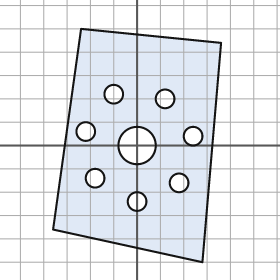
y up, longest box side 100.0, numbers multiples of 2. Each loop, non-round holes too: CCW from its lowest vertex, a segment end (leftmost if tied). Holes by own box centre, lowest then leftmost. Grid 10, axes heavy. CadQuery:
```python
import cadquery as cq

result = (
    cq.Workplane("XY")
    .moveTo(28.0, -50.0)
    .lineTo(36.0, 44.0)
    .lineTo(-24.0, 50.0)
    .lineTo(-36.0, -36.0)
    .close()
    .moveTo(0.0, -24.0)
    .circle(4.0)
    .moveTo(18.0, -16.0)
    .circle(4.0)
    .moveTo(-18.0, -14.0)
    .circle(4.0)
    .moveTo(0.0, 0.0)
    .circle(8.0)
    .moveTo(24.0, 4.0)
    .circle(4.0)
    .moveTo(-22.0, 6.0)
    .circle(4.0)
    .moveTo(12.0, 20.0)
    .circle(4.0)
    .moveTo(-10.0, 22.0)
    .circle(4.0)
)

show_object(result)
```